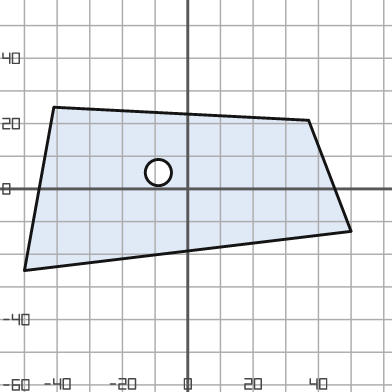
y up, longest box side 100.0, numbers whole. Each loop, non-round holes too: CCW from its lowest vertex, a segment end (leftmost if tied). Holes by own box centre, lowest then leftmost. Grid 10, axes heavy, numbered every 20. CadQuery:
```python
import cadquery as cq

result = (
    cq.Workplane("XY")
    .moveTo(-50.0, -25.0)
    .lineTo(50.0, -13.0)
    .lineTo(37.0, 21.0)
    .lineTo(-41.0, 25.0)
    .close()
    .moveTo(-9.0, 5.0)
    .circle(4.0)
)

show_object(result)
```